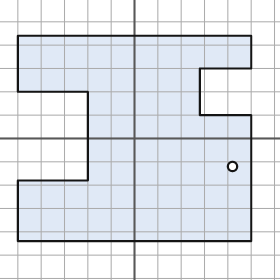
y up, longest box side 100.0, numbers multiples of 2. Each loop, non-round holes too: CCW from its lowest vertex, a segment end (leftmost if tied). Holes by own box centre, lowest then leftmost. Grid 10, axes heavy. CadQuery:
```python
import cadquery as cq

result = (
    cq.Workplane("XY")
    .moveTo(-50.0, -44.0)
    .lineTo(50.0, -44.0)
    .lineTo(50.0, 10.0)
    .lineTo(28.0, 10.0)
    .lineTo(28.0, 30.0)
    .lineTo(50.0, 30.0)
    .lineTo(50.0, 44.0)
    .lineTo(-50.0, 44.0)
    .lineTo(-50.0, 20.0)
    .lineTo(-20.0, 20.0)
    .lineTo(-20.0, -18.0)
    .lineTo(-50.0, -18.0)
    .close()
    .moveTo(42.0, -12.0)
    .circle(2.0)
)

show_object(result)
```